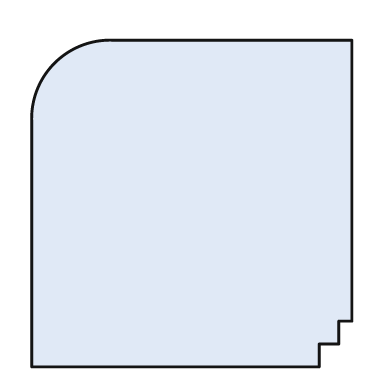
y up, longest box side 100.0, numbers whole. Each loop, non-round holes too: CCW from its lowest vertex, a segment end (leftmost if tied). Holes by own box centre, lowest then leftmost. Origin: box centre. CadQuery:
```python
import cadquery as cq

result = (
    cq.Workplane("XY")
    .moveTo(-49.0, -50.0)
    .lineTo(39.0, -50.0)
    .lineTo(39.0, -43.0)
    .lineTo(45.0, -43.0)
    .lineTo(45.0, -36.0)
    .lineTo(49.0, -36.0)
    .lineTo(49.0, 50.0)
    .lineTo(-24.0, 50.0)
    .threePointArc((-42.0, 43.0), (-49.0, 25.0))
    .close()
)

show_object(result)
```